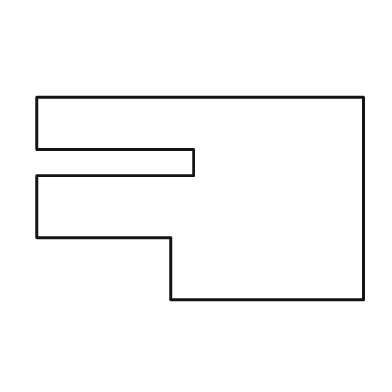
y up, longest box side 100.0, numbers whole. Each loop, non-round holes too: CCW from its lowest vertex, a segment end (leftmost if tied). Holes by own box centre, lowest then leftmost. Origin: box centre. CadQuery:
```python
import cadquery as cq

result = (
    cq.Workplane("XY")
    .moveTo(-9.0, -31.0)
    .lineTo(50.0, -31.0)
    .lineTo(50.0, 31.0)
    .lineTo(-50.0, 31.0)
    .lineTo(-50.0, 15.0)
    .lineTo(-2.0, 15.0)
    .lineTo(-2.0, 7.0)
    .lineTo(-50.0, 7.0)
    .lineTo(-50.0, -12.0)
    .lineTo(-9.0, -12.0)
    .close()
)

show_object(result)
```